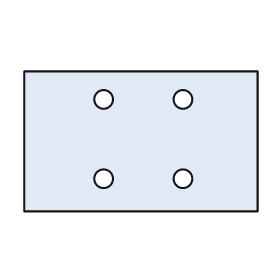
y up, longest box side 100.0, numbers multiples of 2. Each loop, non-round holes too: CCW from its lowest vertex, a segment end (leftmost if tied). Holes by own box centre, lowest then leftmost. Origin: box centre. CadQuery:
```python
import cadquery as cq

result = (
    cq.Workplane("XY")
    .moveTo(-50.0, -30.0)
    .lineTo(50.0, -30.0)
    .lineTo(50.0, 30.0)
    .lineTo(-50.0, 30.0)
    .close()
    .moveTo(-16.0, -16.0)
    .circle(4.0)
    .moveTo(18.0, -16.0)
    .circle(4.0)
    .moveTo(-16.0, 18.0)
    .circle(4.0)
    .moveTo(18.0, 18.0)
    .circle(4.0)
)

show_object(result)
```